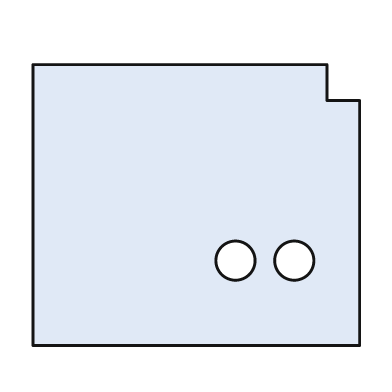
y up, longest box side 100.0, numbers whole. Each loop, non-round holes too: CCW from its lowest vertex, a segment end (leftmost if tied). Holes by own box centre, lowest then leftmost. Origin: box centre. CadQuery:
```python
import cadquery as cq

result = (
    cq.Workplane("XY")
    .moveTo(-50.0, -43.0)
    .lineTo(50.0, -43.0)
    .lineTo(50.0, 32.0)
    .lineTo(40.0, 32.0)
    .lineTo(40.0, 43.0)
    .lineTo(-50.0, 43.0)
    .close()
    .moveTo(12.0, -17.0)
    .circle(6.0)
    .moveTo(30.0, -17.0)
    .circle(6.0)
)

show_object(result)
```